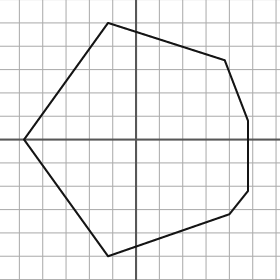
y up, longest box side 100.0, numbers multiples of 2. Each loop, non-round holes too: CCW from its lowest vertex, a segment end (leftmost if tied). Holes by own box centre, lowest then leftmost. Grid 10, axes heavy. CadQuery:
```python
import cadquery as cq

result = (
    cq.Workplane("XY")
    .moveTo(-12.0, -50.0)
    .lineTo(40.0, -32.0)
    .lineTo(48.0, -22.0)
    .lineTo(48.0, 8.0)
    .lineTo(38.0, 34.0)
    .lineTo(-12.0, 50.0)
    .lineTo(-48.0, 0.0)
    .close()
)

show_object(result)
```